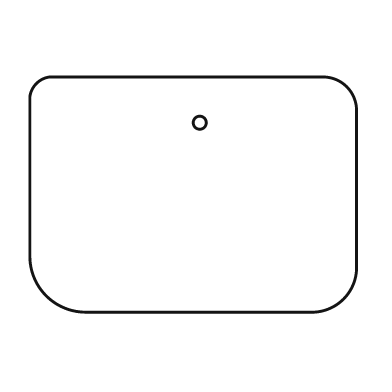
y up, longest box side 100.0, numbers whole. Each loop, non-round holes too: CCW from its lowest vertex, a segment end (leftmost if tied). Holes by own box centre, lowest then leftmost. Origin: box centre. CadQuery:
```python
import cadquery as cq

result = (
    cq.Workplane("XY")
    .moveTo(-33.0, -36.0)
    .lineTo(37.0, -36.0)
    .threePointArc((46.0, -32.0), (50.0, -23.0))
    .lineTo(50.0, 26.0)
    .threePointArc((47.0, 33.0), (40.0, 36.0))
    .lineTo(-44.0, 36.0)
    .threePointArc((-48.0, 34.0), (-50.0, 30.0))
    .lineTo(-50.0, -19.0)
    .threePointArc((-45.0, -31.0), (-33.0, -36.0))
    .close()
    .moveTo(2.0, 22.0)
    .circle(2.0)
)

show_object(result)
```